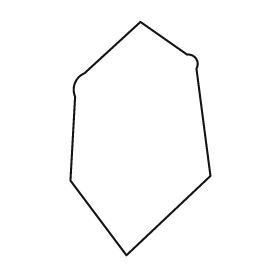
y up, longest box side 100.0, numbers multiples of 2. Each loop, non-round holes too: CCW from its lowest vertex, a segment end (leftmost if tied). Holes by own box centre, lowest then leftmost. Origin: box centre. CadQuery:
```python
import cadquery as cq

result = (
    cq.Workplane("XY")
    .moveTo(-6.0, -50.0)
    .lineTo(30.0, -16.0)
    .lineTo(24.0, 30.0)
    .threePointArc((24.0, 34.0), (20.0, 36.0))
    .lineTo(0.0, 50.0)
    .lineTo(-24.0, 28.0)
    .threePointArc((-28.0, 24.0), (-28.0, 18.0))
    .lineTo(-30.0, -18.0)
    .close()
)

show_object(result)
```